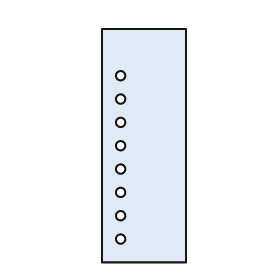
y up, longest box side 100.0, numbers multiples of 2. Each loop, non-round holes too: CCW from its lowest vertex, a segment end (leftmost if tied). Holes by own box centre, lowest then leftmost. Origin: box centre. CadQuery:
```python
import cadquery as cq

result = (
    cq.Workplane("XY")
    .moveTo(-18.0, -50.0)
    .lineTo(18.0, -50.0)
    .lineTo(18.0, 50.0)
    .lineTo(-18.0, 50.0)
    .close()
    .moveTo(-10.0, -40.0)
    .circle(2.0)
    .moveTo(-10.0, -30.0)
    .circle(2.0)
    .moveTo(-10.0, -20.0)
    .circle(2.0)
    .moveTo(-10.0, -10.0)
    .circle(2.0)
    .moveTo(-10.0, 0.0)
    .circle(2.0)
    .moveTo(-10.0, 10.0)
    .circle(2.0)
    .moveTo(-10.0, 20.0)
    .circle(2.0)
    .moveTo(-10.0, 30.0)
    .circle(2.0)
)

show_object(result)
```